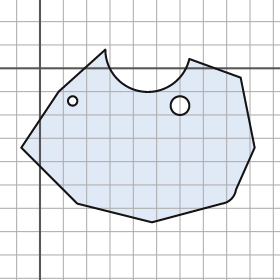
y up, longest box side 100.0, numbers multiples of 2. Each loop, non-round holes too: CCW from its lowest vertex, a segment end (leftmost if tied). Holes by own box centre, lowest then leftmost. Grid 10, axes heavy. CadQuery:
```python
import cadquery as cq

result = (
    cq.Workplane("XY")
    .moveTo(48.0, -66.0)
    .lineTo(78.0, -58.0)
    .threePointArc((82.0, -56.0), (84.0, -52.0))
    .lineTo(92.0, -34.0)
    .lineTo(86.0, -4.0)
    .lineTo(64.0, 4.0)
    .threePointArc((44.0, -10.0), (28.0, 8.0))
    .lineTo(8.0, -10.0)
    .lineTo(-8.0, -34.0)
    .lineTo(16.0, -58.0)
    .close()
    .moveTo(60.0, -16.0)
    .circle(4.0)
    .moveTo(14.0, -14.0)
    .circle(2.0)
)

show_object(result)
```